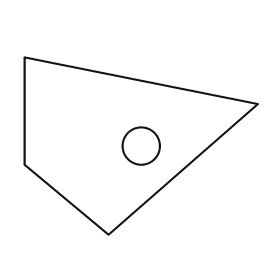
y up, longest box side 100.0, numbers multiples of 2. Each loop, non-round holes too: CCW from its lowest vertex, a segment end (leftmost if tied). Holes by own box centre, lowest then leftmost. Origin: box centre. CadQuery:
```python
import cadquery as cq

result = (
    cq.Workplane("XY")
    .moveTo(-14.0, -38.0)
    .lineTo(50.0, 18.0)
    .lineTo(-50.0, 38.0)
    .lineTo(-50.0, -8.0)
    .close()
    .moveTo(0.0, 0.0)
    .circle(8.0)
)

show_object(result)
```